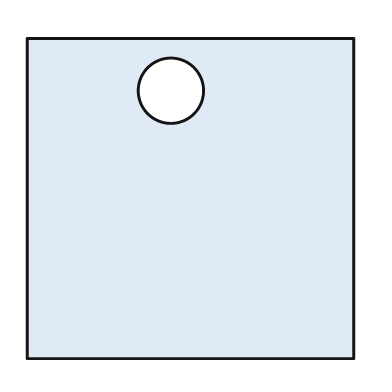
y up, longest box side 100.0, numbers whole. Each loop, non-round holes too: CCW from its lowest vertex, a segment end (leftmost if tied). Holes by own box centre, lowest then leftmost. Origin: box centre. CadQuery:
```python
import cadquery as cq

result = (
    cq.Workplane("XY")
    .moveTo(-50.0, -49.0)
    .lineTo(50.0, -49.0)
    .lineTo(50.0, 49.0)
    .lineTo(-50.0, 49.0)
    .close()
    .moveTo(-6.0, 33.0)
    .circle(10.0)
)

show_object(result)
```